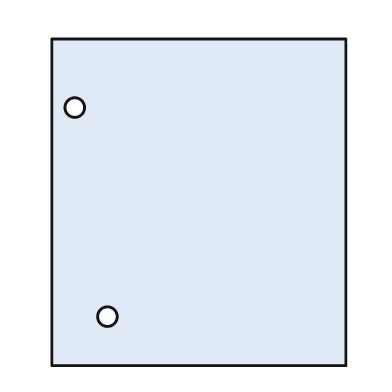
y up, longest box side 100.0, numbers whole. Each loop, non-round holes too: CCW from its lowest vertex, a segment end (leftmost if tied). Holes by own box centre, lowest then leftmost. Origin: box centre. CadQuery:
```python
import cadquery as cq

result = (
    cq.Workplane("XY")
    .moveTo(-45.0, -50.0)
    .lineTo(45.0, -50.0)
    .lineTo(45.0, 50.0)
    .lineTo(-45.0, 50.0)
    .close()
    .moveTo(-28.0, -35.0)
    .circle(3.0)
    .moveTo(-38.0, 29.0)
    .circle(3.0)
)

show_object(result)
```